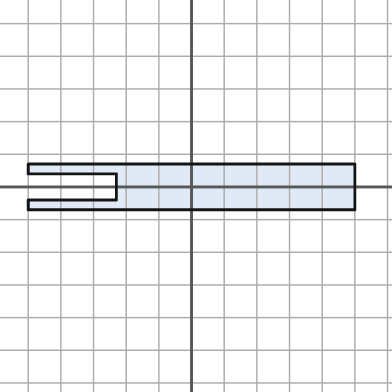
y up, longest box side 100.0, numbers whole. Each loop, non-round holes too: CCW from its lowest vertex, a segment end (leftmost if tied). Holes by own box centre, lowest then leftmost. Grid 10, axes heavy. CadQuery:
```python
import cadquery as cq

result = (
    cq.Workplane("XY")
    .moveTo(-50.0, -7.0)
    .lineTo(50.0, -7.0)
    .lineTo(50.0, 7.0)
    .lineTo(-50.0, 7.0)
    .lineTo(-50.0, 4.0)
    .lineTo(-23.0, 4.0)
    .lineTo(-23.0, -4.0)
    .lineTo(-50.0, -4.0)
    .close()
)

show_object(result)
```